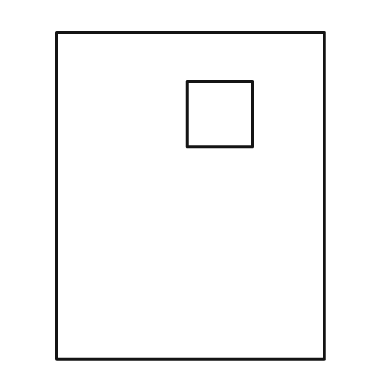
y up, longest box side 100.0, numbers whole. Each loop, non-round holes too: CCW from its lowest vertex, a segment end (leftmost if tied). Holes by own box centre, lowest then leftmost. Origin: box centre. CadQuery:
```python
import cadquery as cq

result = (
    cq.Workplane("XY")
    .moveTo(-41.0, -50.0)
    .lineTo(41.0, -50.0)
    .lineTo(41.0, 50.0)
    .lineTo(-41.0, 50.0)
    .close()
    .moveTo(-1.0, 15.0)
    .lineTo(19.0, 15.0)
    .lineTo(19.0, 35.0)
    .lineTo(-1.0, 35.0)
    .close()
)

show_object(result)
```